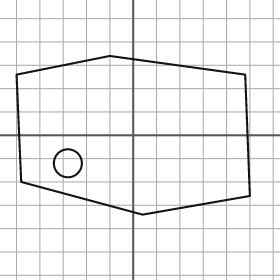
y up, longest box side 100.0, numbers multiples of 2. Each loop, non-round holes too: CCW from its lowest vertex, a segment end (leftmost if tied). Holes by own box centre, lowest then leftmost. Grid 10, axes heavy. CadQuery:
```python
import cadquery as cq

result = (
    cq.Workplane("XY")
    .moveTo(4.0, -34.0)
    .lineTo(50.0, -26.0)
    .lineTo(48.0, 26.0)
    .lineTo(-10.0, 34.0)
    .lineTo(-50.0, 26.0)
    .lineTo(-48.0, -20.0)
    .close()
    .moveTo(-28.0, -12.0)
    .circle(6.0)
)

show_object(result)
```